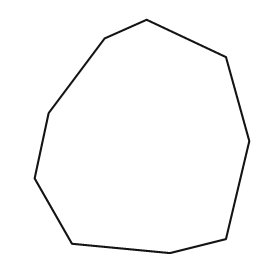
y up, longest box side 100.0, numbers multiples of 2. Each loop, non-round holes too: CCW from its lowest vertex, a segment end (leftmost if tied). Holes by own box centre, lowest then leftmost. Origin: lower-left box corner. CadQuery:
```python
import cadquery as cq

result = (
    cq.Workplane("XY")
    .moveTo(58.0, 0.0)
    .lineTo(82.0, 6.0)
    .lineTo(92.0, 48.0)
    .lineTo(82.0, 84.0)
    .lineTo(48.0, 100.0)
    .lineTo(30.0, 92.0)
    .lineTo(6.0, 60.0)
    .lineTo(0.0, 32.0)
    .lineTo(16.0, 4.0)
    .close()
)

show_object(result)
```